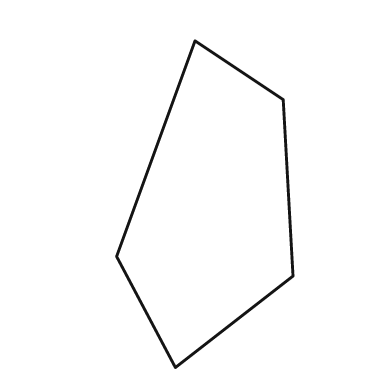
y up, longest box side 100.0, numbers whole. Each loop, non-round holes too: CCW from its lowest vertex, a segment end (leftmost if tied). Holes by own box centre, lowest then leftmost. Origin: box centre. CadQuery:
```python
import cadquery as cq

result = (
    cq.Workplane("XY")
    .moveTo(-9.0, -50.0)
    .lineTo(27.0, -22.0)
    .lineTo(24.0, 32.0)
    .lineTo(-3.0, 50.0)
    .lineTo(-27.0, -16.0)
    .close()
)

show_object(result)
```